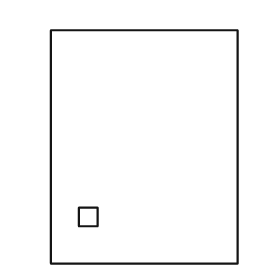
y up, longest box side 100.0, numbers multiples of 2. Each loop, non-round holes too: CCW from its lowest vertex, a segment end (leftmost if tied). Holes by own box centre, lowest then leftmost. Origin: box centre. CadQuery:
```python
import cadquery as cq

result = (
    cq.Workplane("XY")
    .moveTo(-40.0, -50.0)
    .lineTo(40.0, -50.0)
    .lineTo(40.0, 50.0)
    .lineTo(-40.0, 50.0)
    .close()
    .moveTo(-28.0, -34.0)
    .lineTo(-20.0, -34.0)
    .lineTo(-20.0, -26.0)
    .lineTo(-28.0, -26.0)
    .close()
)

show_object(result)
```